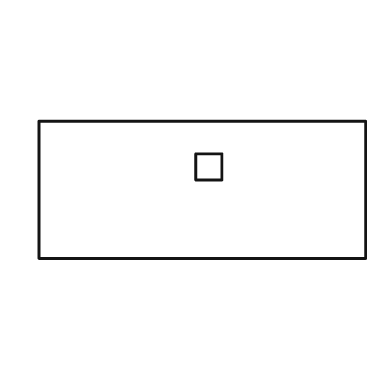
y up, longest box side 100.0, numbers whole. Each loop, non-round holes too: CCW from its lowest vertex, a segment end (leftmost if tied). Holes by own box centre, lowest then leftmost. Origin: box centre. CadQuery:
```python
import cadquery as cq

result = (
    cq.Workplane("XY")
    .moveTo(-50.0, -21.0)
    .lineTo(50.0, -21.0)
    .lineTo(50.0, 21.0)
    .lineTo(-50.0, 21.0)
    .close()
    .moveTo(-2.0, 3.0)
    .lineTo(6.0, 3.0)
    .lineTo(6.0, 11.0)
    .lineTo(-2.0, 11.0)
    .close()
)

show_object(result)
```